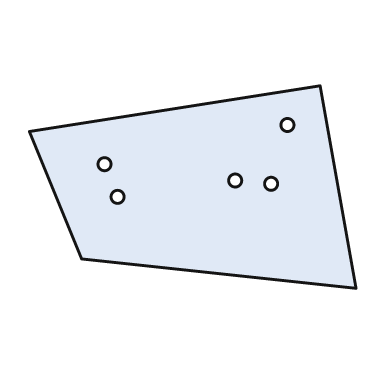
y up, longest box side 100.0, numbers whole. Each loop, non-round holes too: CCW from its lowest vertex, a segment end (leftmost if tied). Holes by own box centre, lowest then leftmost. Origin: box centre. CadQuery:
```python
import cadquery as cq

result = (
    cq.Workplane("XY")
    .moveTo(50.0, -31.0)
    .lineTo(39.0, 31.0)
    .lineTo(-50.0, 17.0)
    .lineTo(-34.0, -22.0)
    .close()
    .moveTo(-23.0, -3.0)
    .circle(2.0)
    .moveTo(24.0, 1.0)
    .circle(2.0)
    .moveTo(13.0, 2.0)
    .circle(2.0)
    .moveTo(-27.0, 7.0)
    .circle(2.0)
    .moveTo(29.0, 19.0)
    .circle(2.0)
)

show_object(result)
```